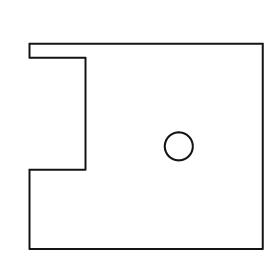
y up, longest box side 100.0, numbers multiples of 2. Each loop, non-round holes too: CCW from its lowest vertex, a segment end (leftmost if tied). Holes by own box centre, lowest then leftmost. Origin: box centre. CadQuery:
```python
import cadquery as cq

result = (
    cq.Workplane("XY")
    .moveTo(-50.0, -44.0)
    .lineTo(50.0, -44.0)
    .lineTo(50.0, 44.0)
    .lineTo(-50.0, 44.0)
    .lineTo(-50.0, 38.0)
    .lineTo(-26.0, 38.0)
    .lineTo(-26.0, -10.0)
    .lineTo(-50.0, -10.0)
    .close()
    .moveTo(14.0, 0.0)
    .circle(6.0)
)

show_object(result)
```